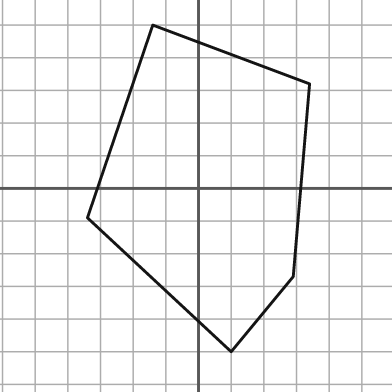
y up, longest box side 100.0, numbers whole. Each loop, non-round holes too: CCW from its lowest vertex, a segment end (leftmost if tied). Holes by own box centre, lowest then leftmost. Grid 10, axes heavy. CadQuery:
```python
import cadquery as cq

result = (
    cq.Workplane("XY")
    .moveTo(10.0, -50.0)
    .lineTo(29.0, -27.0)
    .lineTo(34.0, 32.0)
    .lineTo(-14.0, 50.0)
    .lineTo(-34.0, -9.0)
    .close()
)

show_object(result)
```